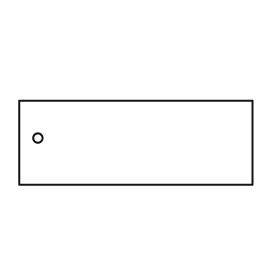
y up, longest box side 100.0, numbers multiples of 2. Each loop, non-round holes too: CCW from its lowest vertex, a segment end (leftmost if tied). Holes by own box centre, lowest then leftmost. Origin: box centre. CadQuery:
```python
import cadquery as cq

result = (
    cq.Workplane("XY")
    .moveTo(-50.0, -18.0)
    .lineTo(50.0, -18.0)
    .lineTo(50.0, 18.0)
    .lineTo(-50.0, 18.0)
    .close()
    .moveTo(-42.0, 2.0)
    .circle(2.0)
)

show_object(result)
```